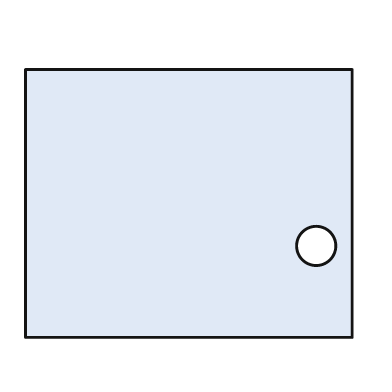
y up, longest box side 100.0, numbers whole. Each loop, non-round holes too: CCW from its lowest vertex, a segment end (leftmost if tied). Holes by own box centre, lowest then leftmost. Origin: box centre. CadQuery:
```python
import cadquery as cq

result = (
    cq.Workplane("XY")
    .moveTo(-50.0, -41.0)
    .lineTo(50.0, -41.0)
    .lineTo(50.0, 41.0)
    .lineTo(-50.0, 41.0)
    .close()
    .moveTo(39.0, -13.0)
    .circle(6.0)
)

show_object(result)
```